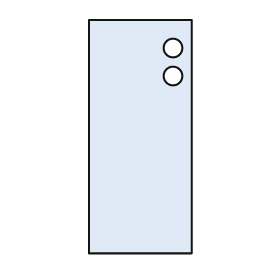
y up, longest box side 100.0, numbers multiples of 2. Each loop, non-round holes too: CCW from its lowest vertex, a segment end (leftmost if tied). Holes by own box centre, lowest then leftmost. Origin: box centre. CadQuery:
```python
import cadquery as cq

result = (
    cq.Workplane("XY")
    .moveTo(-22.0, -50.0)
    .lineTo(22.0, -50.0)
    .lineTo(22.0, 50.0)
    .lineTo(-22.0, 50.0)
    .close()
    .moveTo(14.0, 26.0)
    .circle(4.0)
    .moveTo(14.0, 38.0)
    .circle(4.0)
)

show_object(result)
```